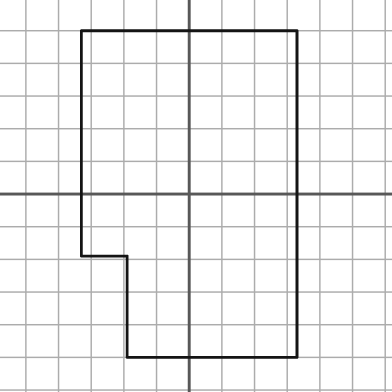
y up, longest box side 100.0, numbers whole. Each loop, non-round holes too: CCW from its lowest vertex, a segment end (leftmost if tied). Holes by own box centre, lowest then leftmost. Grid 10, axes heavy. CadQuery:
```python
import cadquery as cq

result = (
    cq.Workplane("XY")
    .moveTo(-19.0, -50.0)
    .lineTo(33.0, -50.0)
    .lineTo(33.0, 50.0)
    .lineTo(-33.0, 50.0)
    .lineTo(-33.0, -19.0)
    .lineTo(-19.0, -19.0)
    .close()
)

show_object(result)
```